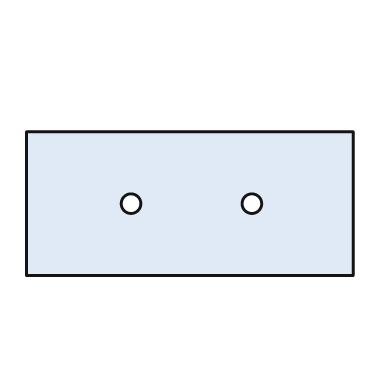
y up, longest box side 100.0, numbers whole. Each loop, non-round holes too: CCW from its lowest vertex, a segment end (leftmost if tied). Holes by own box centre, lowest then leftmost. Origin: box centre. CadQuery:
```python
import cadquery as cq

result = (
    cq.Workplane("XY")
    .moveTo(-50.0, -22.0)
    .lineTo(50.0, -22.0)
    .lineTo(50.0, 22.0)
    .lineTo(-50.0, 22.0)
    .close()
    .moveTo(-18.0, 0.0)
    .circle(3.0)
    .moveTo(19.0, 0.0)
    .circle(3.0)
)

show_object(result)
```